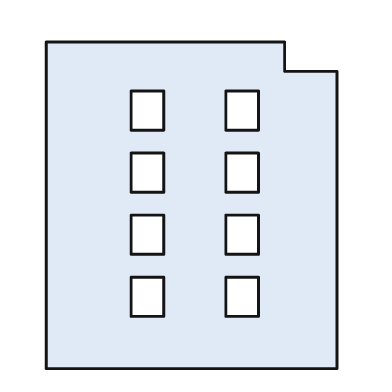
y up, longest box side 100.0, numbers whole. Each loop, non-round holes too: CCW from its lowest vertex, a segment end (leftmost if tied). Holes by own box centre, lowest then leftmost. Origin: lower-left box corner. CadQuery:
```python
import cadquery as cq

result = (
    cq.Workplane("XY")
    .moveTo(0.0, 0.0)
    .lineTo(89.0, 0.0)
    .lineTo(89.0, 91.0)
    .lineTo(73.0, 91.0)
    .lineTo(73.0, 100.0)
    .lineTo(0.0, 100.0)
    .close()
    .moveTo(26.0, 16.0)
    .lineTo(36.0, 16.0)
    .lineTo(36.0, 28.0)
    .lineTo(26.0, 28.0)
    .close()
    .moveTo(55.0, 16.0)
    .lineTo(65.0, 16.0)
    .lineTo(65.0, 28.0)
    .lineTo(55.0, 28.0)
    .close()
    .moveTo(26.0, 35.0)
    .lineTo(36.0, 35.0)
    .lineTo(36.0, 47.0)
    .lineTo(26.0, 47.0)
    .close()
    .moveTo(55.0, 35.0)
    .lineTo(65.0, 35.0)
    .lineTo(65.0, 47.0)
    .lineTo(55.0, 47.0)
    .close()
    .moveTo(26.0, 54.0)
    .lineTo(36.0, 54.0)
    .lineTo(36.0, 66.0)
    .lineTo(26.0, 66.0)
    .close()
    .moveTo(55.0, 54.0)
    .lineTo(65.0, 54.0)
    .lineTo(65.0, 66.0)
    .lineTo(55.0, 66.0)
    .close()
    .moveTo(26.0, 73.0)
    .lineTo(36.0, 73.0)
    .lineTo(36.0, 85.0)
    .lineTo(26.0, 85.0)
    .close()
    .moveTo(55.0, 73.0)
    .lineTo(65.0, 73.0)
    .lineTo(65.0, 85.0)
    .lineTo(55.0, 85.0)
    .close()
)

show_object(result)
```